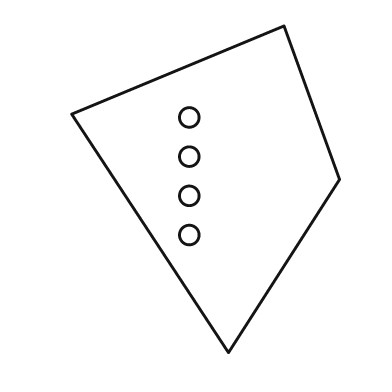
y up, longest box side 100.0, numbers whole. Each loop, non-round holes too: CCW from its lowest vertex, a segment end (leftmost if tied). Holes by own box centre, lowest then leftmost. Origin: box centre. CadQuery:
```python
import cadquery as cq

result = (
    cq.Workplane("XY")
    .moveTo(7.0, -50.0)
    .lineTo(41.0, 3.0)
    .lineTo(24.0, 50.0)
    .lineTo(-41.0, 23.0)
    .close()
    .moveTo(-5.0, -14.0)
    .circle(3.0)
    .moveTo(-5.0, -2.0)
    .circle(3.0)
    .moveTo(-5.0, 10.0)
    .circle(3.0)
    .moveTo(-5.0, 22.0)
    .circle(3.0)
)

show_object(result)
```